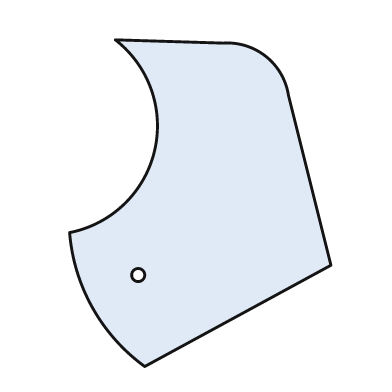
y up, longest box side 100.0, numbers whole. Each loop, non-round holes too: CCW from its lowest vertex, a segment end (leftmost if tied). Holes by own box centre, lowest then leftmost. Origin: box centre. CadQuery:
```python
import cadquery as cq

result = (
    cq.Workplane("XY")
    .moveTo(-17.0, -50.0)
    .lineTo(40.0, -19.0)
    .lineTo(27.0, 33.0)
    .threePointArc((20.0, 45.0), (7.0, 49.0))
    .lineTo(-26.0, 50.0)
    .threePointArc((-14.0, 16.0), (-40.0, -9.0))
    .threePointArc((-33.0, -32.0), (-17.0, -50.0))
    .close()
    .moveTo(-19.0, -22.0)
    .circle(2.0)
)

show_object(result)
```